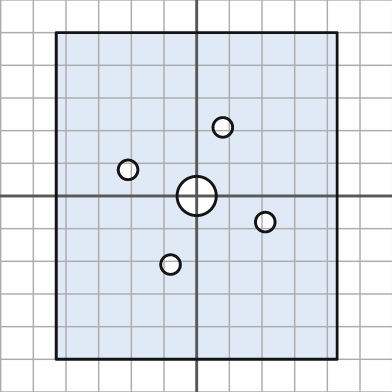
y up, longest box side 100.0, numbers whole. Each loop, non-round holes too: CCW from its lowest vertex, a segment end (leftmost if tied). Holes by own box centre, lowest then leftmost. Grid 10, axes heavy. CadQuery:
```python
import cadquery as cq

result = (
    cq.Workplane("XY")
    .moveTo(-43.0, -50.0)
    .lineTo(43.0, -50.0)
    .lineTo(43.0, 50.0)
    .lineTo(-43.0, 50.0)
    .close()
    .moveTo(-8.0, -21.0)
    .circle(3.0)
    .moveTo(21.0, -8.0)
    .circle(3.0)
    .moveTo(0.0, 0.0)
    .circle(6.0)
    .moveTo(-21.0, 8.0)
    .circle(3.0)
    .moveTo(8.0, 21.0)
    .circle(3.0)
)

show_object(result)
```